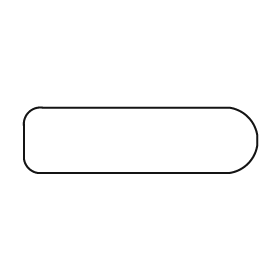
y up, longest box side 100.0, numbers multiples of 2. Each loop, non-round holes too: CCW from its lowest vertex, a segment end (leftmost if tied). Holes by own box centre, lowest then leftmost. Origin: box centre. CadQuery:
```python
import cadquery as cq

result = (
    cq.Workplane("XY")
    .moveTo(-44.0, -14.0)
    .lineTo(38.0, -14.0)
    .threePointArc((46.0, -10.0), (50.0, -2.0))
    .lineTo(50.0, 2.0)
    .threePointArc((46.0, 10.0), (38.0, 14.0))
    .lineTo(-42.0, 14.0)
    .threePointArc((-48.0, 12.0), (-50.0, 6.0))
    .lineTo(-50.0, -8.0)
    .threePointArc((-48.0, -12.0), (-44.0, -14.0))
    .close()
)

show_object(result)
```